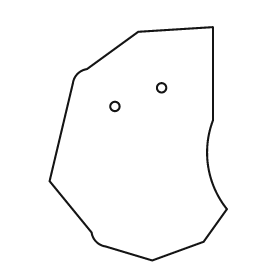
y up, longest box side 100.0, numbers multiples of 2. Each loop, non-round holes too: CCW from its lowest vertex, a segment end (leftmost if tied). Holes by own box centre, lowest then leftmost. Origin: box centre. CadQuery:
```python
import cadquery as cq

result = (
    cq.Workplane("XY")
    .moveTo(6.0, -50.0)
    .lineTo(28.0, -42.0)
    .lineTo(38.0, -28.0)
    .threePointArc((30.0, -10.0), (32.0, 10.0))
    .lineTo(32.0, 50.0)
    .lineTo(0.0, 48.0)
    .lineTo(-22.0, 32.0)
    .threePointArc((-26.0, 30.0), (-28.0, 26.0))
    .lineTo(-38.0, -16.0)
    .lineTo(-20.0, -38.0)
    .threePointArc((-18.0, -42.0), (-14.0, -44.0))
    .close()
    .moveTo(-10.0, 16.0)
    .circle(2.0)
    .moveTo(10.0, 24.0)
    .circle(2.0)
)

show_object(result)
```